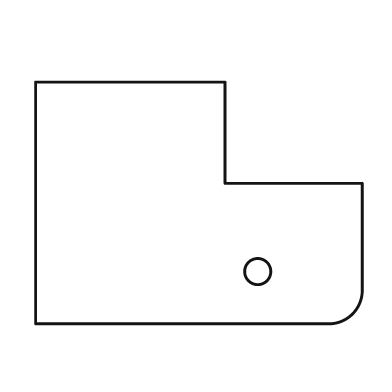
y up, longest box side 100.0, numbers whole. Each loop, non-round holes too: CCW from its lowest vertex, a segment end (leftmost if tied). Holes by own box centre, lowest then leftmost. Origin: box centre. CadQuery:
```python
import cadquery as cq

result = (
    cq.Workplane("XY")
    .moveTo(-50.0, -37.0)
    .lineTo(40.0, -37.0)
    .threePointArc((47.0, -34.0), (50.0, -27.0))
    .lineTo(50.0, 6.0)
    .lineTo(8.0, 6.0)
    .lineTo(8.0, 37.0)
    .lineTo(-50.0, 37.0)
    .close()
    .moveTo(18.0, -21.0)
    .circle(4.0)
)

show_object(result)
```